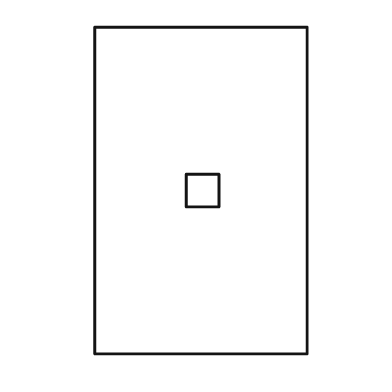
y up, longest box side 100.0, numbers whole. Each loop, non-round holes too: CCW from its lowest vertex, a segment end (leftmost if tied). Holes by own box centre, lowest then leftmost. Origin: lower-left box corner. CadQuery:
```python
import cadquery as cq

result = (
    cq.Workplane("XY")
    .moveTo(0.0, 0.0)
    .lineTo(65.0, 0.0)
    .lineTo(65.0, 100.0)
    .lineTo(0.0, 100.0)
    .close()
    .moveTo(28.0, 45.0)
    .lineTo(38.0, 45.0)
    .lineTo(38.0, 55.0)
    .lineTo(28.0, 55.0)
    .close()
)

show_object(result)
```